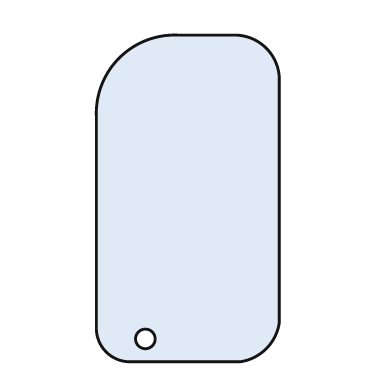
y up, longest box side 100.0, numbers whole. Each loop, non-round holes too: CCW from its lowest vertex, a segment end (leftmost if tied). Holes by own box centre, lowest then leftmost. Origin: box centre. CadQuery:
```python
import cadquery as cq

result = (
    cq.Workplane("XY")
    .moveTo(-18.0, -50.0)
    .lineTo(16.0, -50.0)
    .threePointArc((24.0, -46.0), (28.0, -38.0))
    .lineTo(28.0, 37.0)
    .threePointArc((24.0, 46.0), (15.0, 50.0))
    .lineTo(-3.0, 50.0)
    .threePointArc((-21.0, 43.0), (-28.0, 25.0))
    .lineTo(-28.0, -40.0)
    .threePointArc((-25.0, -47.0), (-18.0, -50.0))
    .close()
    .moveTo(-13.0, -43.0)
    .circle(3.0)
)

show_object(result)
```